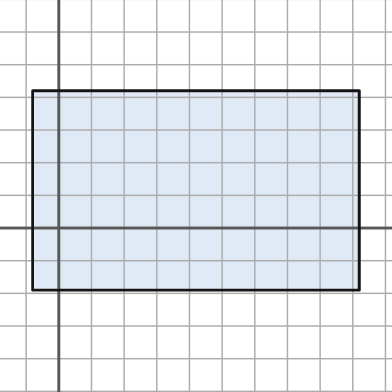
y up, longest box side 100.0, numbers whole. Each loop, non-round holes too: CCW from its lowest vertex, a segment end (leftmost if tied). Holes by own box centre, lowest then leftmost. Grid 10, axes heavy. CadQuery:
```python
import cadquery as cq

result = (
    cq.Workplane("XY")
    .moveTo(-8.0, -19.0)
    .lineTo(92.0, -19.0)
    .lineTo(92.0, 42.0)
    .lineTo(-8.0, 42.0)
    .close()
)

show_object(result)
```